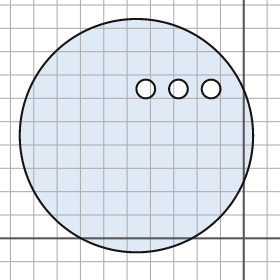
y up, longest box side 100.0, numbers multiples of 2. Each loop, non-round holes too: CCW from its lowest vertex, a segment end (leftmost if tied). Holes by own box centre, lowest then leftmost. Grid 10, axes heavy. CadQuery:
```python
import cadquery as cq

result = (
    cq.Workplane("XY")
    .moveTo(-46.0, 44.0)
    .circle(50.0)
    .moveTo(-42.0, 64.0)
    .circle(4.0)
    .moveTo(-28.0, 64.0)
    .circle(4.0)
    .moveTo(-14.0, 64.0)
    .circle(4.0)
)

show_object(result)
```